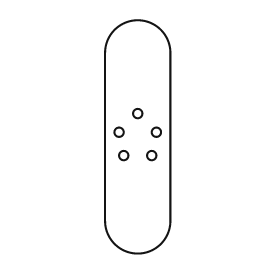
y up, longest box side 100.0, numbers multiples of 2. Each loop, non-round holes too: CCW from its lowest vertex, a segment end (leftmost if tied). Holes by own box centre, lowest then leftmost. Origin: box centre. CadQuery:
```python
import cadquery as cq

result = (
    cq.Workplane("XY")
    .moveTo(-14.0, -36.0)
    .threePointArc((0.0, -50.0), (14.0, -36.0))
    .lineTo(14.0, 36.0)
    .threePointArc((0.0, 50.0), (-14.0, 36.0))
    .close()
    .moveTo(-6.0, -8.0)
    .circle(2.0)
    .moveTo(6.0, -8.0)
    .circle(2.0)
    .moveTo(-8.0, 2.0)
    .circle(2.0)
    .moveTo(8.0, 2.0)
    .circle(2.0)
    .moveTo(0.0, 10.0)
    .circle(2.0)
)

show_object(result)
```